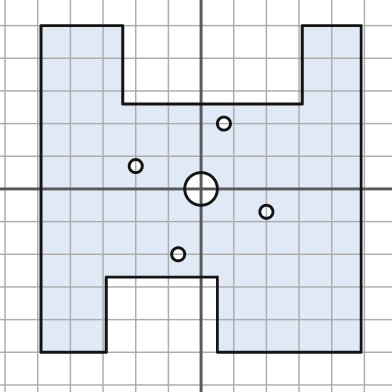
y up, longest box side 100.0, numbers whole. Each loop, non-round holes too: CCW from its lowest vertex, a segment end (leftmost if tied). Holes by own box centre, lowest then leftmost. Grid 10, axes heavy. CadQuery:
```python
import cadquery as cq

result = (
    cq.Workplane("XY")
    .moveTo(-49.0, -50.0)
    .lineTo(-29.0, -50.0)
    .lineTo(-29.0, -27.0)
    .lineTo(5.0, -27.0)
    .lineTo(5.0, -50.0)
    .lineTo(49.0, -50.0)
    .lineTo(49.0, 50.0)
    .lineTo(31.0, 50.0)
    .lineTo(31.0, 26.0)
    .lineTo(-24.0, 26.0)
    .lineTo(-24.0, 50.0)
    .lineTo(-49.0, 50.0)
    .close()
    .moveTo(-7.0, -20.0)
    .circle(2.0)
    .moveTo(20.0, -7.0)
    .circle(2.0)
    .moveTo(0.0, 0.0)
    .circle(5.0)
    .moveTo(-20.0, 7.0)
    .circle(2.0)
    .moveTo(7.0, 20.0)
    .circle(2.0)
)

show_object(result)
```